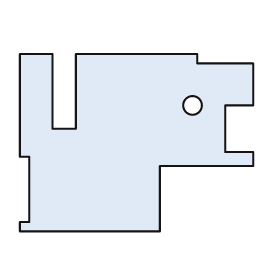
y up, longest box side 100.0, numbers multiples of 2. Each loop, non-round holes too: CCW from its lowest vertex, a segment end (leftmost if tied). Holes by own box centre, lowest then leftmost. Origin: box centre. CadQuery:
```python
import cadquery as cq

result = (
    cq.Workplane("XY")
    .moveTo(-50.0, -38.0)
    .lineTo(10.0, -38.0)
    .lineTo(10.0, -10.0)
    .lineTo(50.0, -10.0)
    .lineTo(50.0, -4.0)
    .lineTo(38.0, -4.0)
    .lineTo(38.0, 16.0)
    .lineTo(50.0, 16.0)
    .lineTo(50.0, 34.0)
    .lineTo(26.0, 34.0)
    .lineTo(26.0, 38.0)
    .lineTo(-26.0, 38.0)
    .lineTo(-26.0, 6.0)
    .lineTo(-36.0, 6.0)
    .lineTo(-36.0, 38.0)
    .lineTo(-50.0, 38.0)
    .lineTo(-50.0, -6.0)
    .lineTo(-46.0, -6.0)
    .lineTo(-46.0, -34.0)
    .lineTo(-50.0, -34.0)
    .close()
    .moveTo(24.0, 16.0)
    .circle(4.0)
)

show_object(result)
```